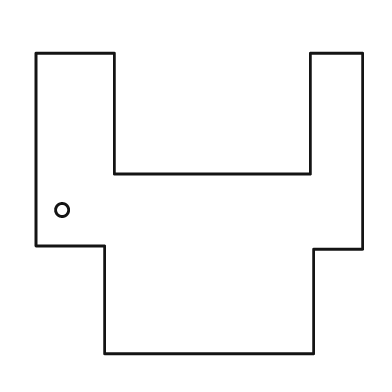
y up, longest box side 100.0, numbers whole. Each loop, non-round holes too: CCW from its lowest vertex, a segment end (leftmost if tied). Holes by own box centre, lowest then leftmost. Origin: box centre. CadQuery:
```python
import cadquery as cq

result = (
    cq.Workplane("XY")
    .moveTo(-29.0, -46.0)
    .lineTo(35.0, -46.0)
    .lineTo(35.0, -14.0)
    .lineTo(50.0, -14.0)
    .lineTo(50.0, 46.0)
    .lineTo(34.0, 46.0)
    .lineTo(34.0, 9.0)
    .lineTo(-26.0, 9.0)
    .lineTo(-26.0, 46.0)
    .lineTo(-50.0, 46.0)
    .lineTo(-50.0, -13.0)
    .lineTo(-29.0, -13.0)
    .close()
    .moveTo(-42.0, -2.0)
    .circle(2.0)
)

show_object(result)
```